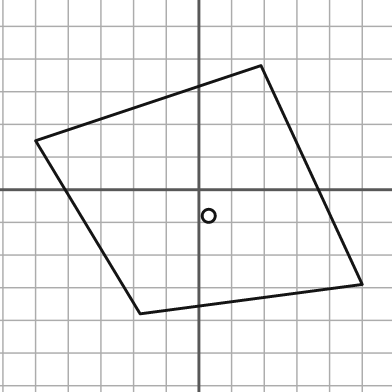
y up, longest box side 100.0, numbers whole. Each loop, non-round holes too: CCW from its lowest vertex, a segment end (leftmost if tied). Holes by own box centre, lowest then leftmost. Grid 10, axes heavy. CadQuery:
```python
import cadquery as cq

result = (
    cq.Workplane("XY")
    .moveTo(-18.0, -38.0)
    .lineTo(50.0, -29.0)
    .lineTo(19.0, 38.0)
    .lineTo(-50.0, 15.0)
    .close()
    .moveTo(3.0, -8.0)
    .circle(2.0)
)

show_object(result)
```